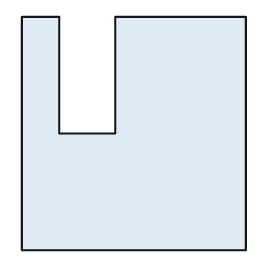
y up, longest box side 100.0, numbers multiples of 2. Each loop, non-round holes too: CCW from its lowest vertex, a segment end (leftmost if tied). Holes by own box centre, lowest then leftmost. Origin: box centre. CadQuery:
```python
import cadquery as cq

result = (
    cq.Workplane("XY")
    .moveTo(-48.0, -50.0)
    .lineTo(48.0, -50.0)
    .lineTo(48.0, 50.0)
    .lineTo(-8.0, 50.0)
    .lineTo(-8.0, 0.0)
    .lineTo(-32.0, 0.0)
    .lineTo(-32.0, 50.0)
    .lineTo(-48.0, 50.0)
    .close()
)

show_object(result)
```